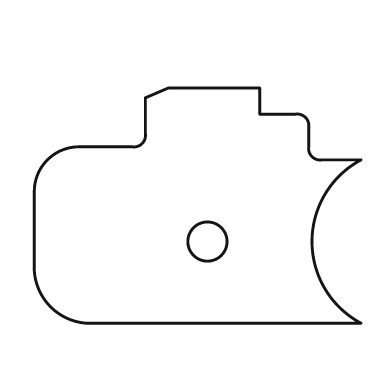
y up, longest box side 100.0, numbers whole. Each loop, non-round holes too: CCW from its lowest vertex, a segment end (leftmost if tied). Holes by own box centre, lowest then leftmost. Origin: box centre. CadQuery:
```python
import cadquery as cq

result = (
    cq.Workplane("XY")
    .moveTo(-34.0, -36.0)
    .lineTo(50.0, -36.0)
    .threePointArc((35.0, -11.0), (50.0, 14.0))
    .lineTo(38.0, 14.0)
    .threePointArc((35.0, 15.0), (34.0, 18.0))
    .lineTo(34.0, 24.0)
    .threePointArc((33.0, 27.0), (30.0, 28.0))
    .lineTo(19.0, 28.0)
    .lineTo(19.0, 36.0)
    .lineTo(-9.0, 36.0)
    .lineTo(-16.0, 33.0)
    .lineTo(-16.0, 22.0)
    .threePointArc((-17.0, 19.0), (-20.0, 18.0))
    .lineTo(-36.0, 18.0)
    .threePointArc((-46.0, 14.0), (-50.0, 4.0))
    .lineTo(-50.0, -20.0)
    .threePointArc((-45.0, -31.0), (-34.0, -36.0))
    .close()
    .moveTo(3.0, -11.0)
    .circle(6.0)
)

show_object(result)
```